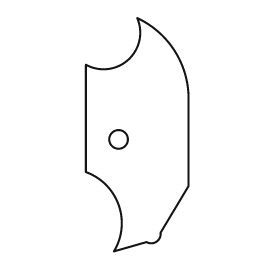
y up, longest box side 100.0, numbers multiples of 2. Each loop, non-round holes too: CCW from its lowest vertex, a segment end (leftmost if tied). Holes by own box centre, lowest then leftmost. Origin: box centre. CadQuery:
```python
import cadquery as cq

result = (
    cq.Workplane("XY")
    .moveTo(-10.0, -50.0)
    .lineTo(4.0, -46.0)
    .threePointArc((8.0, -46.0), (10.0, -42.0))
    .lineTo(22.0, -22.0)
    .lineTo(22.0, 16.0)
    .threePointArc((16.0, 36.0), (0.0, 50.0))
    .threePointArc((-4.0, 32.0), (-22.0, 30.0))
    .lineTo(-22.0, -16.0)
    .threePointArc((-8.0, -30.0), (-10.0, -50.0))
    .close()
    .moveTo(-8.0, -2.0)
    .circle(4.0)
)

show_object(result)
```